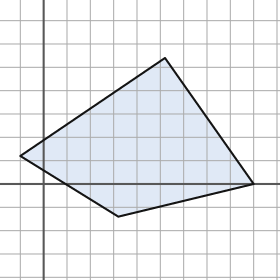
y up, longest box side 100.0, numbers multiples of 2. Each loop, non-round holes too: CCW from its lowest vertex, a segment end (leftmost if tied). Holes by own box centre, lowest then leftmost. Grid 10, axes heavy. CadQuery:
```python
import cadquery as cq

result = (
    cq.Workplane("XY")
    .moveTo(32.0, -14.0)
    .lineTo(90.0, 0.0)
    .lineTo(52.0, 54.0)
    .lineTo(-10.0, 12.0)
    .close()
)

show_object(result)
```